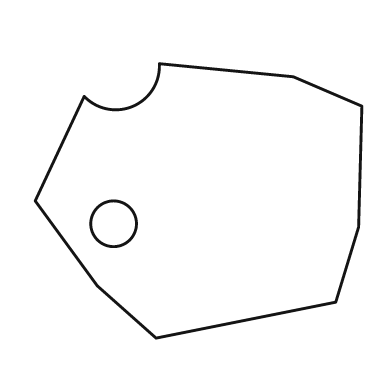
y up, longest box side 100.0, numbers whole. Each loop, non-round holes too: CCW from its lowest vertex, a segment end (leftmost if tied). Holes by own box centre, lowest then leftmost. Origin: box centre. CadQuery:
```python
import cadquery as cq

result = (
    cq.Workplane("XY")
    .moveTo(-13.0, -42.0)
    .lineTo(42.0, -31.0)
    .lineTo(49.0, -8.0)
    .lineTo(50.0, 29.0)
    .lineTo(29.0, 38.0)
    .lineTo(-12.0, 42.0)
    .threePointArc((-20.0, 29.0), (-35.0, 32.0))
    .lineTo(-50.0, 0.0)
    .lineTo(-31.0, -26.0)
    .close()
    .moveTo(-26.0, -7.0)
    .circle(7.0)
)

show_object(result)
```